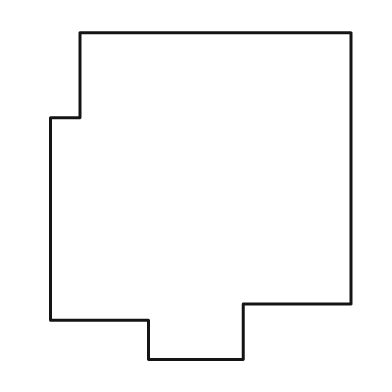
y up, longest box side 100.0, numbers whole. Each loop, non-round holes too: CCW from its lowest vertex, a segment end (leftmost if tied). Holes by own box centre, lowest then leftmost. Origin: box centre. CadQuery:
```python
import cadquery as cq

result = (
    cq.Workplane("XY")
    .moveTo(-16.0, -50.0)
    .lineTo(13.0, -50.0)
    .lineTo(13.0, -33.0)
    .lineTo(46.0, -33.0)
    .lineTo(46.0, 50.0)
    .lineTo(-37.0, 50.0)
    .lineTo(-37.0, 24.0)
    .lineTo(-46.0, 24.0)
    .lineTo(-46.0, -38.0)
    .lineTo(-16.0, -38.0)
    .close()
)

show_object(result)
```